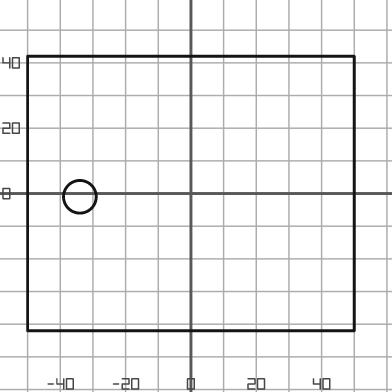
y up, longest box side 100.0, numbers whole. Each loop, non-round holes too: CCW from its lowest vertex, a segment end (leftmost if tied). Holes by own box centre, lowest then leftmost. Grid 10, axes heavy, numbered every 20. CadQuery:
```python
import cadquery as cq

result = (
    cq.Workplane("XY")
    .moveTo(-50.0, -42.0)
    .lineTo(50.0, -42.0)
    .lineTo(50.0, 42.0)
    .lineTo(-50.0, 42.0)
    .close()
    .moveTo(-34.0, -1.0)
    .circle(5.0)
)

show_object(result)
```